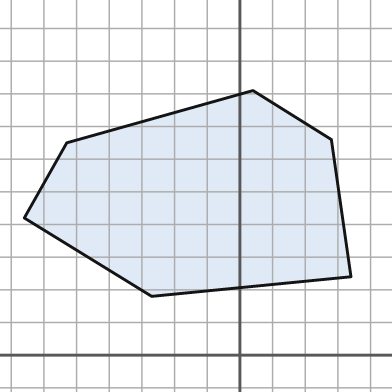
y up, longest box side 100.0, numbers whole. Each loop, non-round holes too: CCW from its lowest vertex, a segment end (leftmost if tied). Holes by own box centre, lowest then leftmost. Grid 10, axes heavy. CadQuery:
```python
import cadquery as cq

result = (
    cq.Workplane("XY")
    .moveTo(-27.0, 18.0)
    .lineTo(34.0, 24.0)
    .lineTo(28.0, 66.0)
    .lineTo(4.0, 81.0)
    .lineTo(-53.0, 65.0)
    .lineTo(-66.0, 42.0)
    .close()
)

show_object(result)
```